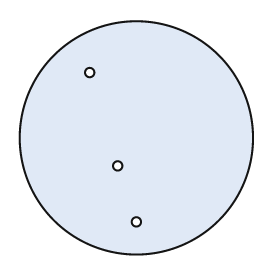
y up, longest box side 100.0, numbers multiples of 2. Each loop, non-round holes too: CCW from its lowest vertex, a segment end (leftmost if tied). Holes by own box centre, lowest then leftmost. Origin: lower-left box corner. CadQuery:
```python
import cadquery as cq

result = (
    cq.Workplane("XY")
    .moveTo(50.0, 50.0)
    .circle(50.0)
    .moveTo(50.0, 14.0)
    .circle(2.0)
    .moveTo(42.0, 38.0)
    .circle(2.0)
    .moveTo(30.0, 78.0)
    .circle(2.0)
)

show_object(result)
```